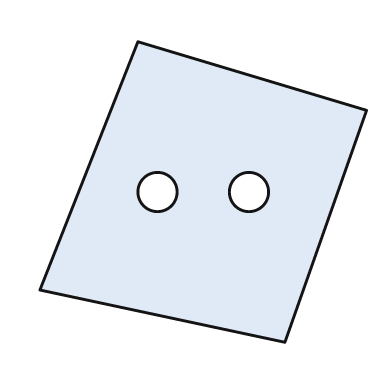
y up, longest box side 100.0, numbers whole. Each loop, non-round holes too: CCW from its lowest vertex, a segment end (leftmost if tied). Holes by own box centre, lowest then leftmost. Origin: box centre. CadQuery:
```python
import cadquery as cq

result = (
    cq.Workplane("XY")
    .moveTo(25.0, -46.0)
    .lineTo(50.0, 25.0)
    .lineTo(-20.0, 46.0)
    .lineTo(-50.0, -30.0)
    .close()
    .moveTo(-14.0, 0.0)
    .circle(6.0)
    .moveTo(14.0, 0.0)
    .circle(6.0)
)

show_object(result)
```